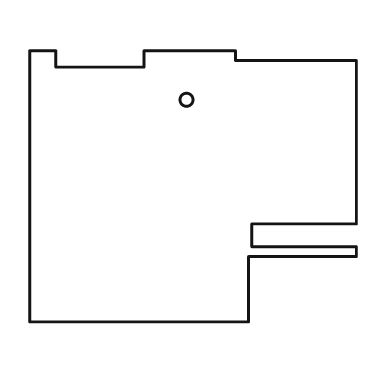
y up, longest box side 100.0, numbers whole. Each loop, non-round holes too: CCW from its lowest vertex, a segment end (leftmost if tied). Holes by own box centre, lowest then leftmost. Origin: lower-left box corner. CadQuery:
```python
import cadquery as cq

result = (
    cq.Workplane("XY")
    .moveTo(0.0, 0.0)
    .lineTo(67.0, 0.0)
    .lineTo(67.0, 20.0)
    .lineTo(100.0, 20.0)
    .lineTo(100.0, 23.0)
    .lineTo(68.0, 23.0)
    .lineTo(68.0, 30.0)
    .lineTo(100.0, 30.0)
    .lineTo(100.0, 80.0)
    .lineTo(63.0, 80.0)
    .lineTo(63.0, 83.0)
    .lineTo(35.0, 83.0)
    .lineTo(35.0, 78.0)
    .lineTo(8.0, 78.0)
    .lineTo(8.0, 83.0)
    .lineTo(0.0, 83.0)
    .close()
    .moveTo(48.0, 68.0)
    .circle(2.0)
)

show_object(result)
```